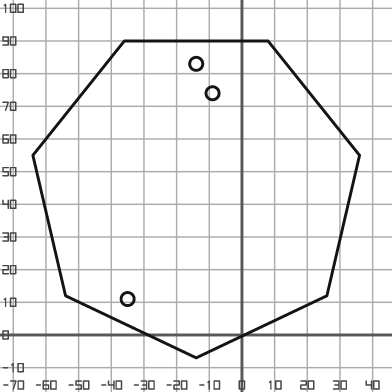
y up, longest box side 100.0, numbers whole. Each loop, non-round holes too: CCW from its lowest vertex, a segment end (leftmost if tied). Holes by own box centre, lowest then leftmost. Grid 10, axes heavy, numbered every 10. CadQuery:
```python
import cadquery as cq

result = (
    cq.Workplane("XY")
    .moveTo(-14.0, -7.0)
    .lineTo(26.0, 12.0)
    .lineTo(36.0, 55.0)
    .lineTo(8.0, 90.0)
    .lineTo(-36.0, 90.0)
    .lineTo(-64.0, 55.0)
    .lineTo(-54.0, 12.0)
    .close()
    .moveTo(-35.0, 11.0)
    .circle(2.0)
    .moveTo(-9.0, 74.0)
    .circle(2.0)
    .moveTo(-14.0, 83.0)
    .circle(2.0)
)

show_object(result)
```